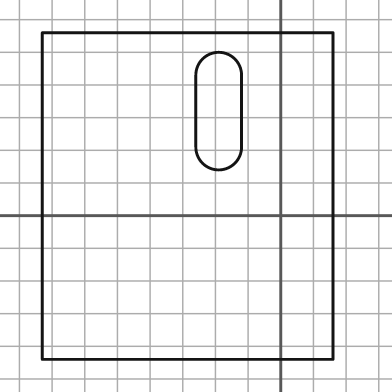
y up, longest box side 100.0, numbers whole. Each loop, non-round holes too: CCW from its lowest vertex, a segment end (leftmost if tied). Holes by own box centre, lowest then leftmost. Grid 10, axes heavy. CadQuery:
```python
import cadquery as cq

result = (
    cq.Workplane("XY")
    .moveTo(-73.0, -44.0)
    .lineTo(16.0, -44.0)
    .lineTo(16.0, 56.0)
    .lineTo(-73.0, 56.0)
    .close()
    .moveTo(-26.0, 21.0)
    .threePointArc((-19.0, 14.0), (-12.0, 21.0))
    .lineTo(-12.0, 43.0)
    .threePointArc((-19.0, 50.0), (-26.0, 43.0))
    .close()
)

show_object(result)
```